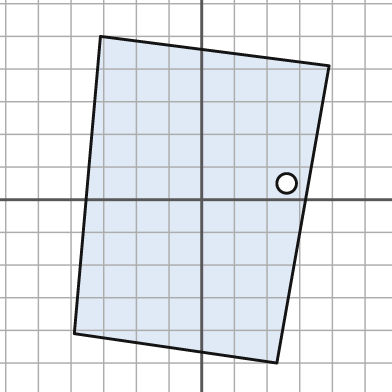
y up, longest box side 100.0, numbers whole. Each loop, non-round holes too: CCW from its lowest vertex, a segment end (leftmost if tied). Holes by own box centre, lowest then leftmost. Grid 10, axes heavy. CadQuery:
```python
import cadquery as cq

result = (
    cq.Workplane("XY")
    .moveTo(23.0, -50.0)
    .lineTo(39.0, 41.0)
    .lineTo(-31.0, 50.0)
    .lineTo(-39.0, -41.0)
    .close()
    .moveTo(26.0, 5.0)
    .circle(3.0)
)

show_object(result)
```